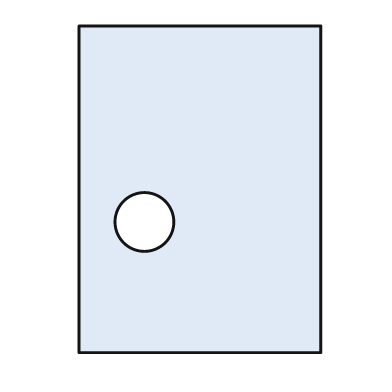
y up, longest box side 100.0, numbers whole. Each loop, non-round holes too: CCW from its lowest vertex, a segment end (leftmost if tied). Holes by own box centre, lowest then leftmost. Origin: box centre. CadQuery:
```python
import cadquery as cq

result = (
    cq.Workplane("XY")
    .moveTo(-37.0, -50.0)
    .lineTo(37.0, -50.0)
    .lineTo(37.0, 50.0)
    .lineTo(-37.0, 50.0)
    .close()
    .moveTo(-17.0, -10.0)
    .circle(9.0)
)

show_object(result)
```